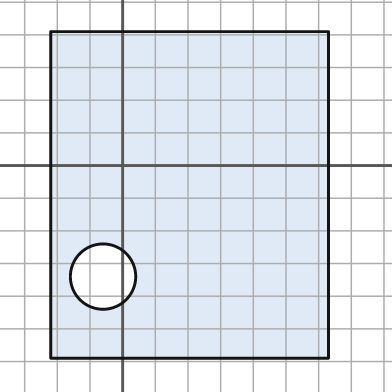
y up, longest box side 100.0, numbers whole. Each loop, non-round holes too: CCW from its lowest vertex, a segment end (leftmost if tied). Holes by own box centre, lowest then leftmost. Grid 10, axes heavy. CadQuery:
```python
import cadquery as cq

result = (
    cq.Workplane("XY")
    .moveTo(-22.0, -59.0)
    .lineTo(63.0, -59.0)
    .lineTo(63.0, 41.0)
    .lineTo(-22.0, 41.0)
    .close()
    .moveTo(-6.0, -34.0)
    .circle(10.0)
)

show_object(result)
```